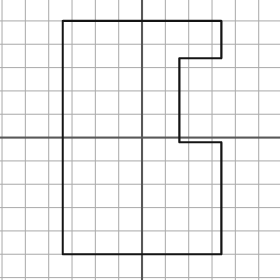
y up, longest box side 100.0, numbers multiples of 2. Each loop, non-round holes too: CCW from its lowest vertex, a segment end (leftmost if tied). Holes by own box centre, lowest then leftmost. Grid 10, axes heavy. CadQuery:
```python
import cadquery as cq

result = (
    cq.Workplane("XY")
    .moveTo(-34.0, -50.0)
    .lineTo(34.0, -50.0)
    .lineTo(34.0, -2.0)
    .lineTo(16.0, -2.0)
    .lineTo(16.0, 34.0)
    .lineTo(34.0, 34.0)
    .lineTo(34.0, 50.0)
    .lineTo(-34.0, 50.0)
    .close()
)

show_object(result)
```